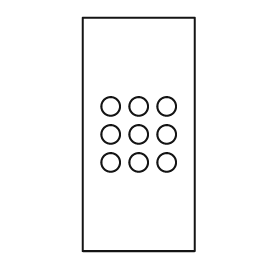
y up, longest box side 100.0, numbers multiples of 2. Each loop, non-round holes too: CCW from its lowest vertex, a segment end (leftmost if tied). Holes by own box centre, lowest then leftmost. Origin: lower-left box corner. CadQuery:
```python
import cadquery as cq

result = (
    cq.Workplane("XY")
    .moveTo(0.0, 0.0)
    .lineTo(48.0, 0.0)
    .lineTo(48.0, 100.0)
    .lineTo(0.0, 100.0)
    .close()
    .moveTo(12.0, 38.0)
    .circle(4.0)
    .moveTo(24.0, 38.0)
    .circle(4.0)
    .moveTo(36.0, 38.0)
    .circle(4.0)
    .moveTo(12.0, 50.0)
    .circle(4.0)
    .moveTo(24.0, 50.0)
    .circle(4.0)
    .moveTo(36.0, 50.0)
    .circle(4.0)
    .moveTo(12.0, 62.0)
    .circle(4.0)
    .moveTo(24.0, 62.0)
    .circle(4.0)
    .moveTo(36.0, 62.0)
    .circle(4.0)
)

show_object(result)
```